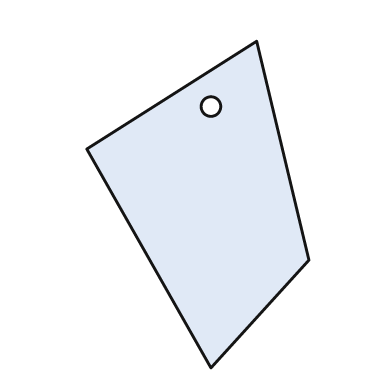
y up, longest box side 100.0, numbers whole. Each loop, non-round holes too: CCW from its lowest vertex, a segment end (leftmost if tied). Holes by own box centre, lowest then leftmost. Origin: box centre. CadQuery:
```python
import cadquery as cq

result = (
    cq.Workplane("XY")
    .moveTo(4.0, -50.0)
    .lineTo(34.0, -17.0)
    .lineTo(18.0, 50.0)
    .lineTo(-34.0, 17.0)
    .close()
    .moveTo(4.0, 30.0)
    .circle(3.0)
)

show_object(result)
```